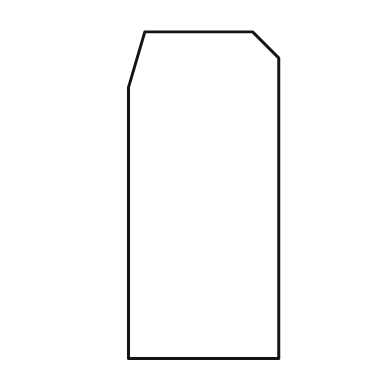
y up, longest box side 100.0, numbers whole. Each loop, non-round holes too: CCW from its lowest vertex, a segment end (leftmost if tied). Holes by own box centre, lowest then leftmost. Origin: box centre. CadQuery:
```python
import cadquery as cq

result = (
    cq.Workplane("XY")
    .moveTo(-23.0, -50.0)
    .lineTo(23.0, -50.0)
    .lineTo(23.0, 42.0)
    .lineTo(15.0, 50.0)
    .lineTo(-18.0, 50.0)
    .lineTo(-23.0, 33.0)
    .close()
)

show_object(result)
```